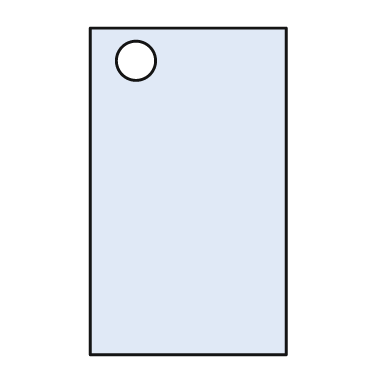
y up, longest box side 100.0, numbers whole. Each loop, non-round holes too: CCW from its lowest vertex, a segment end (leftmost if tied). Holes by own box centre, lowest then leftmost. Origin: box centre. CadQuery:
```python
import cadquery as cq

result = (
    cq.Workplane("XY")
    .moveTo(-30.0, -50.0)
    .lineTo(30.0, -50.0)
    .lineTo(30.0, 50.0)
    .lineTo(-30.0, 50.0)
    .close()
    .moveTo(-16.0, 40.0)
    .circle(6.0)
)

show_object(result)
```